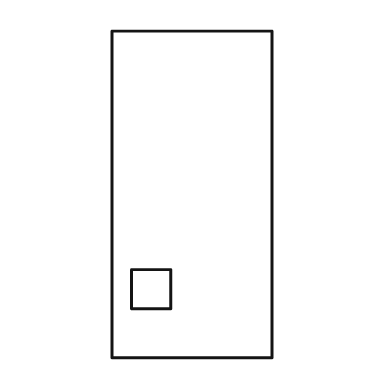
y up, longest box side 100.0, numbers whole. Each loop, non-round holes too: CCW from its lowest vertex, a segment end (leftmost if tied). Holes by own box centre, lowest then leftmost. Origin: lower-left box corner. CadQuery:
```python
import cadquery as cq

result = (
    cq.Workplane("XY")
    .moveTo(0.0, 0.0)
    .lineTo(49.0, 0.0)
    .lineTo(49.0, 100.0)
    .lineTo(0.0, 100.0)
    .close()
    .moveTo(6.0, 15.0)
    .lineTo(18.0, 15.0)
    .lineTo(18.0, 27.0)
    .lineTo(6.0, 27.0)
    .close()
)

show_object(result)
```